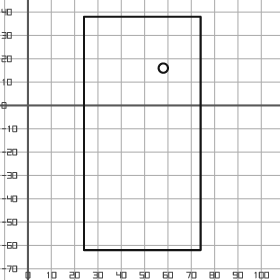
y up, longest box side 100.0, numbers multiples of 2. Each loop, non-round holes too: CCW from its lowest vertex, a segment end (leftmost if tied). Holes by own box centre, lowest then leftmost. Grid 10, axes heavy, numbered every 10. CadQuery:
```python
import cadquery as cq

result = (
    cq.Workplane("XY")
    .moveTo(24.0, -62.0)
    .lineTo(74.0, -62.0)
    .lineTo(74.0, 38.0)
    .lineTo(24.0, 38.0)
    .close()
    .moveTo(58.0, 16.0)
    .circle(2.0)
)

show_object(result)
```